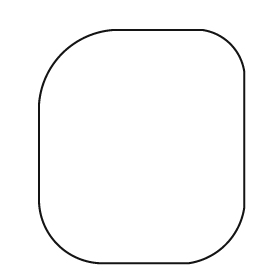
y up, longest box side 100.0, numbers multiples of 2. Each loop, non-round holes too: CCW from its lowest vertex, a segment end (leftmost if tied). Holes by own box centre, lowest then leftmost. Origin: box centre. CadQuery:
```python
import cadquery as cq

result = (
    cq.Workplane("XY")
    .moveTo(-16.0, -50.0)
    .lineTo(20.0, -50.0)
    .threePointArc((36.0, -42.0), (44.0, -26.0))
    .lineTo(44.0, 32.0)
    .threePointArc((38.0, 44.0), (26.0, 50.0))
    .lineTo(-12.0, 50.0)
    .threePointArc((-34.0, 40.0), (-44.0, 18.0))
    .lineTo(-44.0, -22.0)
    .threePointArc((-36.0, -42.0), (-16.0, -50.0))
    .close()
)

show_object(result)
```